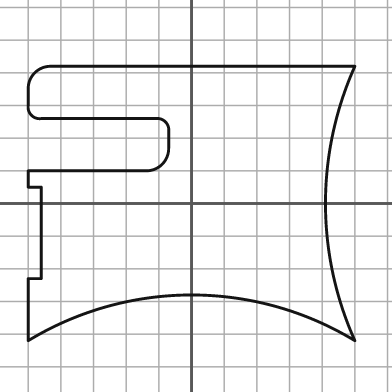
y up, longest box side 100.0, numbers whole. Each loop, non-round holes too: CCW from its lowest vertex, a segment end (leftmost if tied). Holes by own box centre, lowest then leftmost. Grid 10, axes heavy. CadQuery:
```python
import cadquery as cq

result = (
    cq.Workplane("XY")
    .moveTo(-50.0, -42.0)
    .threePointArc((0.0, -28.0), (50.0, -42.0))
    .threePointArc((41.0, 0.0), (50.0, 42.0))
    .lineTo(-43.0, 42.0)
    .threePointArc((-48.0, 40.0), (-50.0, 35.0))
    .lineTo(-50.0, 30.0)
    .threePointArc((-49.0, 27.0), (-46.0, 26.0))
    .lineTo(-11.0, 26.0)
    .threePointArc((-8.0, 25.0), (-7.0, 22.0))
    .lineTo(-7.0, 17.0)
    .threePointArc((-9.0, 12.0), (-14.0, 10.0))
    .lineTo(-50.0, 10.0)
    .lineTo(-50.0, 5.0)
    .lineTo(-46.0, 5.0)
    .lineTo(-46.0, -23.0)
    .lineTo(-50.0, -23.0)
    .close()
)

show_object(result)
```